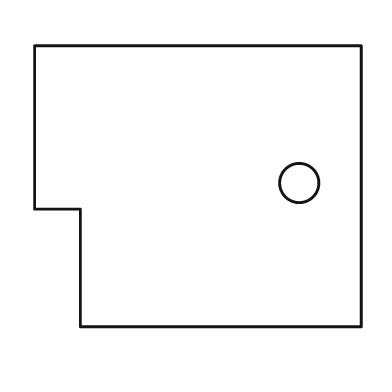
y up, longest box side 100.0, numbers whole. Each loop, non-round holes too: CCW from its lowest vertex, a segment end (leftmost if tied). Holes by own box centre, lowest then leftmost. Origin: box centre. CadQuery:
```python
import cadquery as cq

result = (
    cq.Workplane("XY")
    .moveTo(-36.0, -43.0)
    .lineTo(50.0, -43.0)
    .lineTo(50.0, 43.0)
    .lineTo(-50.0, 43.0)
    .lineTo(-50.0, -7.0)
    .lineTo(-36.0, -7.0)
    .close()
    .moveTo(31.0, 1.0)
    .circle(6.0)
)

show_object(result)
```